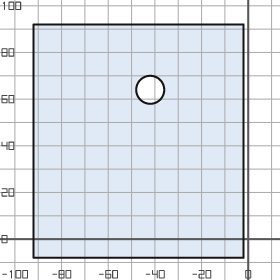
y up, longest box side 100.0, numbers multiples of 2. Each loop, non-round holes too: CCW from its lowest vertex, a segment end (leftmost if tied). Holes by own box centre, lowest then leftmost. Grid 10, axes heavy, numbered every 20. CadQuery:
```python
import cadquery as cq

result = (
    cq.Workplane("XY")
    .moveTo(-92.0, -8.0)
    .lineTo(-2.0, -8.0)
    .lineTo(-2.0, 92.0)
    .lineTo(-92.0, 92.0)
    .close()
    .moveTo(-42.0, 64.0)
    .circle(6.0)
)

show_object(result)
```